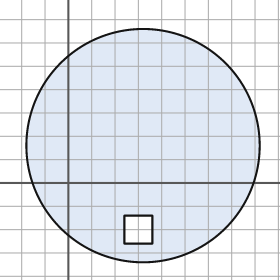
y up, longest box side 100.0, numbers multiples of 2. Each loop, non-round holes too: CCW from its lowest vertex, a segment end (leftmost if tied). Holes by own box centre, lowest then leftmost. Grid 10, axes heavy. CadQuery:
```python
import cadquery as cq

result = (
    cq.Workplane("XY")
    .moveTo(32.0, 16.0)
    .circle(50.0)
    .moveTo(24.0, -26.0)
    .lineTo(36.0, -26.0)
    .lineTo(36.0, -14.0)
    .lineTo(24.0, -14.0)
    .close()
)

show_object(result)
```